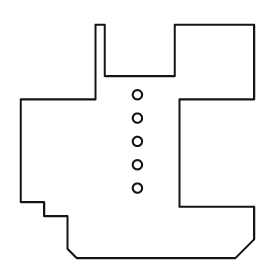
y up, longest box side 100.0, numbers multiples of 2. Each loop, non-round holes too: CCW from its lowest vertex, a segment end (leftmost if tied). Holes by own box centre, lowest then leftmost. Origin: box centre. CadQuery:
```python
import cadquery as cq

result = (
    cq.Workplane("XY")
    .moveTo(-26.0, -50.0)
    .lineTo(42.0, -50.0)
    .lineTo(50.0, -42.0)
    .lineTo(50.0, -28.0)
    .lineTo(18.0, -28.0)
    .lineTo(18.0, 18.0)
    .lineTo(50.0, 18.0)
    .lineTo(50.0, 50.0)
    .lineTo(16.0, 50.0)
    .lineTo(16.0, 28.0)
    .lineTo(-14.0, 28.0)
    .lineTo(-14.0, 50.0)
    .lineTo(-18.0, 50.0)
    .lineTo(-18.0, 18.0)
    .lineTo(-50.0, 18.0)
    .lineTo(-50.0, -26.0)
    .lineTo(-40.0, -26.0)
    .lineTo(-40.0, -32.0)
    .lineTo(-30.0, -32.0)
    .lineTo(-30.0, -46.0)
    .close()
    .moveTo(0.0, -20.0)
    .circle(2.0)
    .moveTo(0.0, -10.0)
    .circle(2.0)
    .moveTo(0.0, 0.0)
    .circle(2.0)
    .moveTo(0.0, 10.0)
    .circle(2.0)
    .moveTo(0.0, 20.0)
    .circle(2.0)
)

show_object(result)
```